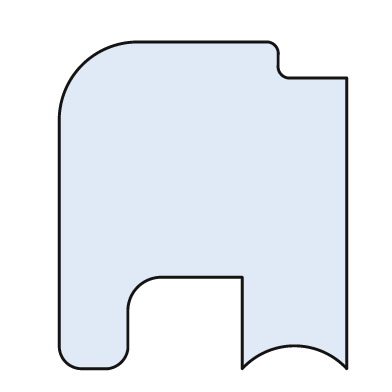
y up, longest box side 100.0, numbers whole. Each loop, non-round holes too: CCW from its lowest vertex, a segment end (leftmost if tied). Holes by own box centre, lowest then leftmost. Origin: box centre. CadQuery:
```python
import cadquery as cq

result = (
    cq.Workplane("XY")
    .moveTo(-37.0, -50.0)
    .lineTo(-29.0, -50.0)
    .threePointArc((-25.0, -48.0), (-23.0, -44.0))
    .lineTo(-23.0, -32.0)
    .threePointArc((-20.0, -25.0), (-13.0, -22.0))
    .lineTo(12.0, -22.0)
    .lineTo(12.0, -50.0)
    .threePointArc((28.0, -43.0), (44.0, -50.0))
    .lineTo(44.0, 39.0)
    .lineTo(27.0, 39.0)
    .threePointArc((24.0, 40.0), (23.0, 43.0))
    .lineTo(23.0, 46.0)
    .threePointArc((22.0, 49.0), (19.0, 50.0))
    .lineTo(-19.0, 50.0)
    .threePointArc((-37.0, 43.0), (-44.0, 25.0))
    .lineTo(-44.0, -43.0)
    .threePointArc((-42.0, -48.0), (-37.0, -50.0))
    .close()
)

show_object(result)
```